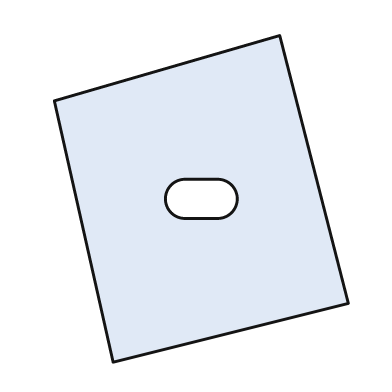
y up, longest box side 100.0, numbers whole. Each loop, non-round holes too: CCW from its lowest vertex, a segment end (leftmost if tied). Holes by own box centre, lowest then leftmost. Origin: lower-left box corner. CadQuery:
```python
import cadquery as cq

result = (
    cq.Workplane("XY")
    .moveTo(18.0, 0.0)
    .lineTo(90.0, 18.0)
    .lineTo(69.0, 100.0)
    .lineTo(0.0, 80.0)
    .close()
    .moveTo(40.0, 44.0)
    .lineTo(50.0, 44.0)
    .threePointArc((56.0, 50.0), (50.0, 56.0))
    .lineTo(40.0, 56.0)
    .threePointArc((34.0, 50.0), (40.0, 44.0))
    .close()
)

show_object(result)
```